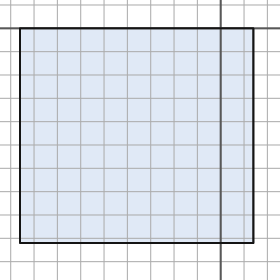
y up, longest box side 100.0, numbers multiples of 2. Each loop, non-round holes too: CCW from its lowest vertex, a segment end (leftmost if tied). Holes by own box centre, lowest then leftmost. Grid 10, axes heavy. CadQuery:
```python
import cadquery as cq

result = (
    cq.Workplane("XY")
    .moveTo(-86.0, -92.0)
    .lineTo(14.0, -92.0)
    .lineTo(14.0, 0.0)
    .lineTo(-86.0, 0.0)
    .close()
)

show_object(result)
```